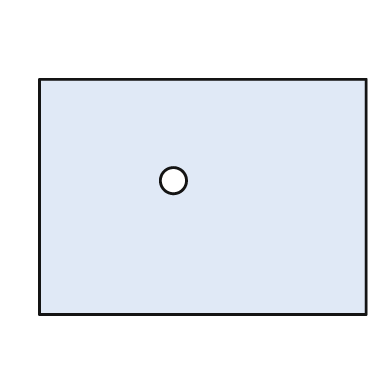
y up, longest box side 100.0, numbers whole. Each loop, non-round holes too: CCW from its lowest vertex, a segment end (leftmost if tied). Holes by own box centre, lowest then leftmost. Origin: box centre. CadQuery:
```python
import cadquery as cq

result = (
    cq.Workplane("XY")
    .moveTo(-50.0, -36.0)
    .lineTo(50.0, -36.0)
    .lineTo(50.0, 36.0)
    .lineTo(-50.0, 36.0)
    .close()
    .moveTo(-9.0, 5.0)
    .circle(4.0)
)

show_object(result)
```